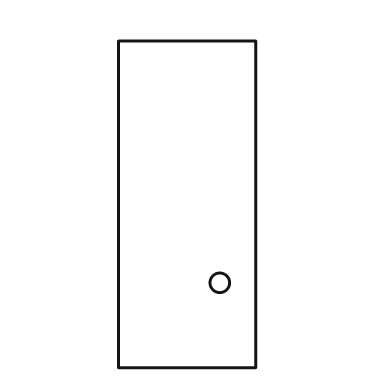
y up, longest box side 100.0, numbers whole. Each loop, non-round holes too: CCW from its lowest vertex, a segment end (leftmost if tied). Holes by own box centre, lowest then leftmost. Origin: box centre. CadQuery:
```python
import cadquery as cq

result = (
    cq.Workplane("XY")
    .moveTo(-21.0, -50.0)
    .lineTo(21.0, -50.0)
    .lineTo(21.0, 50.0)
    .lineTo(-21.0, 50.0)
    .close()
    .moveTo(10.0, -24.0)
    .circle(3.0)
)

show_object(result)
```